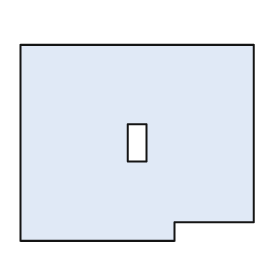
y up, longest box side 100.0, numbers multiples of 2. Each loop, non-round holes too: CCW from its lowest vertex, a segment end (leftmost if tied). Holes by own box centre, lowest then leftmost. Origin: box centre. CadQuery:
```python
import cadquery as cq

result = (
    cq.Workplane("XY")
    .moveTo(-50.0, -42.0)
    .lineTo(16.0, -42.0)
    .lineTo(16.0, -34.0)
    .lineTo(50.0, -34.0)
    .lineTo(50.0, 42.0)
    .lineTo(-50.0, 42.0)
    .close()
    .moveTo(-4.0, -8.0)
    .lineTo(4.0, -8.0)
    .lineTo(4.0, 8.0)
    .lineTo(-4.0, 8.0)
    .close()
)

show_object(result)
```